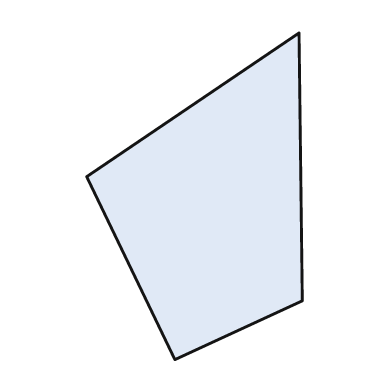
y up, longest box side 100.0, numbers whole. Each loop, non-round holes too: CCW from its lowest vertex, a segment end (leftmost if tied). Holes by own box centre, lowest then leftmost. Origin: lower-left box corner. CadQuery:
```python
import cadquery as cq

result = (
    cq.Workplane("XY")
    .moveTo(27.0, 0.0)
    .lineTo(66.0, 18.0)
    .lineTo(65.0, 100.0)
    .lineTo(0.0, 56.0)
    .close()
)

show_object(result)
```